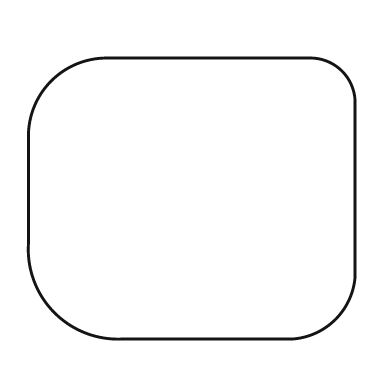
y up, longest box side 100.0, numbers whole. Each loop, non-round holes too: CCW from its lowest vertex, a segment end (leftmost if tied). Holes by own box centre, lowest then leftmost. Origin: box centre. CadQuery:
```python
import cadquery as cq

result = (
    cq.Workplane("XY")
    .moveTo(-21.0, -43.0)
    .lineTo(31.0, -43.0)
    .threePointArc((44.0, -37.0), (50.0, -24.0))
    .lineTo(50.0, 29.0)
    .threePointArc((46.0, 39.0), (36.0, 43.0))
    .lineTo(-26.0, 43.0)
    .threePointArc((-43.0, 36.0), (-50.0, 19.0))
    .lineTo(-50.0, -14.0)
    .threePointArc((-42.0, -35.0), (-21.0, -43.0))
    .close()
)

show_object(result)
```